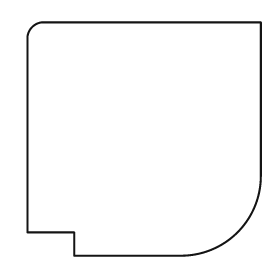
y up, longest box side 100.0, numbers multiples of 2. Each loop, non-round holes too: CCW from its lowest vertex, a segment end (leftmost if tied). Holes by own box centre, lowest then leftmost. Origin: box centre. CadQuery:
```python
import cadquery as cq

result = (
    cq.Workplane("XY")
    .moveTo(-30.0, -50.0)
    .lineTo(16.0, -50.0)
    .threePointArc((40.0, -40.0), (50.0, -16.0))
    .lineTo(50.0, 50.0)
    .lineTo(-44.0, 50.0)
    .threePointArc((-48.0, 48.0), (-50.0, 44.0))
    .lineTo(-50.0, -40.0)
    .lineTo(-30.0, -40.0)
    .close()
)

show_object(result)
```